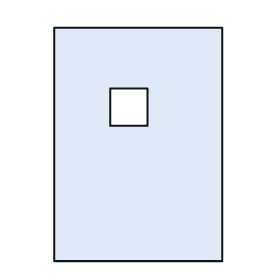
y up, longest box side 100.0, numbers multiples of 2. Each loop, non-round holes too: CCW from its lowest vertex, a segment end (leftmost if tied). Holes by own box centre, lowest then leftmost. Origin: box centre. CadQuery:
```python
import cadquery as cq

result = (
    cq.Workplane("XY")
    .moveTo(-36.0, -50.0)
    .lineTo(36.0, -50.0)
    .lineTo(36.0, 50.0)
    .lineTo(-36.0, 50.0)
    .close()
    .moveTo(-12.0, 8.0)
    .lineTo(4.0, 8.0)
    .lineTo(4.0, 24.0)
    .lineTo(-12.0, 24.0)
    .close()
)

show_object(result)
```